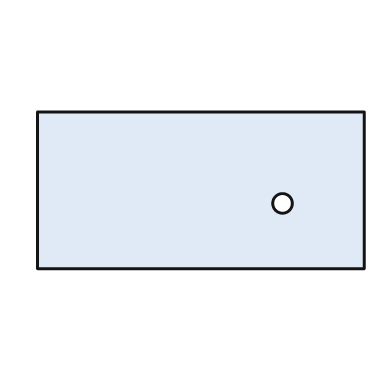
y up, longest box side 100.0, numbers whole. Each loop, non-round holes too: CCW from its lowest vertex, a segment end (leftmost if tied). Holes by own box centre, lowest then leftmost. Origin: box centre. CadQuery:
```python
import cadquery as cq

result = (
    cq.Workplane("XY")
    .moveTo(-50.0, -24.0)
    .lineTo(50.0, -24.0)
    .lineTo(50.0, 24.0)
    .lineTo(-50.0, 24.0)
    .close()
    .moveTo(25.0, -4.0)
    .circle(3.0)
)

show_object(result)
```